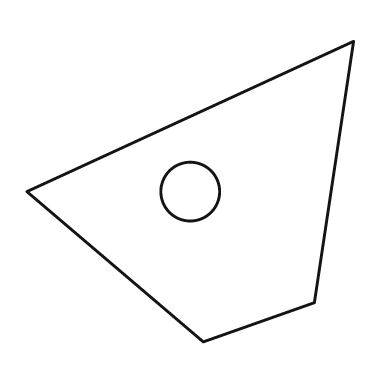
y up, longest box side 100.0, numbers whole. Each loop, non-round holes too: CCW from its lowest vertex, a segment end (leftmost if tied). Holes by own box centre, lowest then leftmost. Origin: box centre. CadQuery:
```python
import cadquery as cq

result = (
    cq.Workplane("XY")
    .moveTo(4.0, -46.0)
    .lineTo(38.0, -34.0)
    .lineTo(50.0, 46.0)
    .lineTo(-50.0, 0.0)
    .close()
    .moveTo(0.0, 0.0)
    .circle(9.0)
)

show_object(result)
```